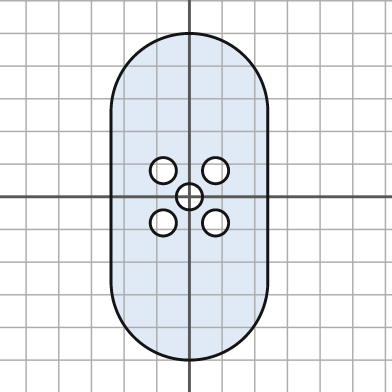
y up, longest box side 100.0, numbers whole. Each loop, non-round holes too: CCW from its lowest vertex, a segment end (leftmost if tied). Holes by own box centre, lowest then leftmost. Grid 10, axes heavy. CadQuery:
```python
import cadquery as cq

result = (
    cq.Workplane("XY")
    .moveTo(-24.0, -26.0)
    .threePointArc((0.0, -50.0), (24.0, -26.0))
    .lineTo(24.0, 26.0)
    .threePointArc((0.0, 50.0), (-24.0, 26.0))
    .close()
    .moveTo(-8.0, -8.0)
    .circle(4.0)
    .moveTo(8.0, -8.0)
    .circle(4.0)
    .moveTo(0.0, 0.0)
    .circle(4.0)
    .moveTo(-8.0, 8.0)
    .circle(4.0)
    .moveTo(8.0, 8.0)
    .circle(4.0)
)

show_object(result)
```